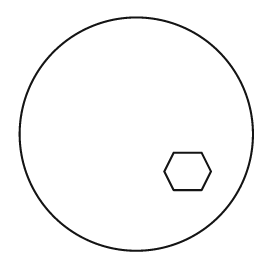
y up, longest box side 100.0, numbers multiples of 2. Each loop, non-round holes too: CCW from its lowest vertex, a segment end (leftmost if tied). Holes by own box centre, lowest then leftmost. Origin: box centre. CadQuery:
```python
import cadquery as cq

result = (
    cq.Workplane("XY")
    .moveTo(0.0, 0.0)
    .circle(50.0)
    .moveTo(16.0, -24.0)
    .lineTo(28.0, -24.0)
    .lineTo(32.0, -16.0)
    .lineTo(28.0, -8.0)
    .lineTo(16.0, -8.0)
    .lineTo(12.0, -16.0)
    .close()
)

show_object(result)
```